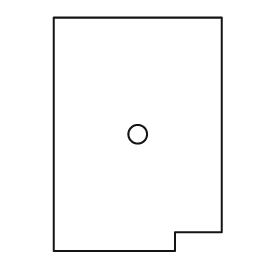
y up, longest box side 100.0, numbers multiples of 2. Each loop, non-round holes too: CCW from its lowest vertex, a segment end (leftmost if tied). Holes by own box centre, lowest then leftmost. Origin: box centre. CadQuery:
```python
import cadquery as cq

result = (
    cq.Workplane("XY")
    .moveTo(-36.0, -50.0)
    .lineTo(16.0, -50.0)
    .lineTo(16.0, -42.0)
    .lineTo(36.0, -42.0)
    .lineTo(36.0, 50.0)
    .lineTo(-36.0, 50.0)
    .close()
    .moveTo(0.0, 0.0)
    .circle(4.0)
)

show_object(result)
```